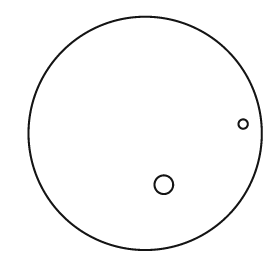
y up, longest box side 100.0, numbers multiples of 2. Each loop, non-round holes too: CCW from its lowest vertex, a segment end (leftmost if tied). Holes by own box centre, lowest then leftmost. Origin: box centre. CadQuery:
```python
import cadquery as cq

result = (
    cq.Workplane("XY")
    .moveTo(0.0, 0.0)
    .circle(50.0)
    .moveTo(8.0, -22.0)
    .circle(4.0)
    .moveTo(42.0, 4.0)
    .circle(2.0)
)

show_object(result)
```